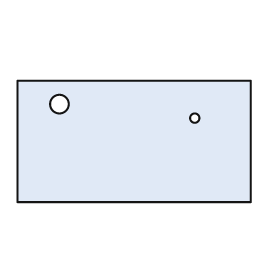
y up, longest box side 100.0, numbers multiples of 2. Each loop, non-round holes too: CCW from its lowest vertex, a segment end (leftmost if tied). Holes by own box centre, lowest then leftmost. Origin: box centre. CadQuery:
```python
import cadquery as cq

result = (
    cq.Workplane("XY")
    .moveTo(-50.0, -26.0)
    .lineTo(50.0, -26.0)
    .lineTo(50.0, 26.0)
    .lineTo(-50.0, 26.0)
    .close()
    .moveTo(26.0, 10.0)
    .circle(2.0)
    .moveTo(-32.0, 16.0)
    .circle(4.0)
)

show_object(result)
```